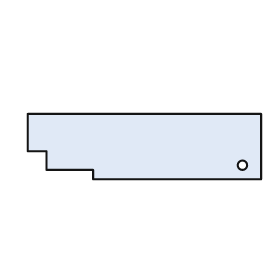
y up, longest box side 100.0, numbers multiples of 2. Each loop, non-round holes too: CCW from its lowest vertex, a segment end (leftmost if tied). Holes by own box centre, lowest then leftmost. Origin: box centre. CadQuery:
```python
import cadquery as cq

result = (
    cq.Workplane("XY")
    .moveTo(-22.0, -14.0)
    .lineTo(50.0, -14.0)
    .lineTo(50.0, 14.0)
    .lineTo(-50.0, 14.0)
    .lineTo(-50.0, -2.0)
    .lineTo(-42.0, -2.0)
    .lineTo(-42.0, -10.0)
    .lineTo(-22.0, -10.0)
    .close()
    .moveTo(42.0, -8.0)
    .circle(2.0)
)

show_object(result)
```